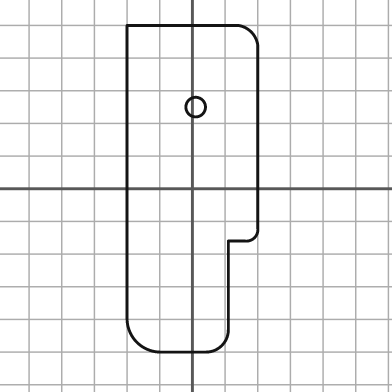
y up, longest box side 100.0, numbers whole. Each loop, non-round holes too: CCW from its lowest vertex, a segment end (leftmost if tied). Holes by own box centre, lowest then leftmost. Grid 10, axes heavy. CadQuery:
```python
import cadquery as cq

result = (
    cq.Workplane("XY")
    .moveTo(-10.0, -50.0)
    .lineTo(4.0, -50.0)
    .threePointArc((9.0, -48.0), (11.0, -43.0))
    .lineTo(11.0, -16.0)
    .lineTo(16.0, -16.0)
    .threePointArc((19.0, -15.0), (20.0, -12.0))
    .lineTo(20.0, 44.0)
    .threePointArc((18.0, 48.0), (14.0, 50.0))
    .lineTo(-20.0, 50.0)
    .lineTo(-20.0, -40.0)
    .threePointArc((-17.0, -47.0), (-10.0, -50.0))
    .close()
    .moveTo(1.0, 25.0)
    .circle(3.0)
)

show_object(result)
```